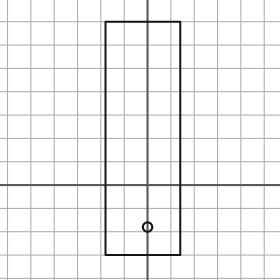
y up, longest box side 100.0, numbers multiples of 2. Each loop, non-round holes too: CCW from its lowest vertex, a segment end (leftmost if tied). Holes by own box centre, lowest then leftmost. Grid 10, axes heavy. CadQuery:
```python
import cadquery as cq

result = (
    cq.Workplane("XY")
    .moveTo(-18.0, -30.0)
    .lineTo(14.0, -30.0)
    .lineTo(14.0, 70.0)
    .lineTo(-18.0, 70.0)
    .close()
    .moveTo(0.0, -18.0)
    .circle(2.0)
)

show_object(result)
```